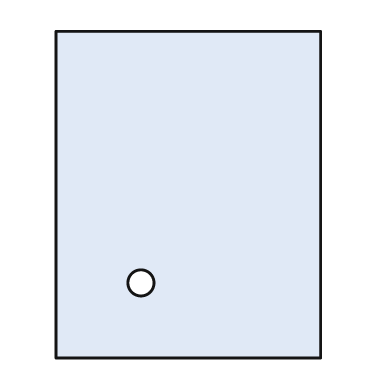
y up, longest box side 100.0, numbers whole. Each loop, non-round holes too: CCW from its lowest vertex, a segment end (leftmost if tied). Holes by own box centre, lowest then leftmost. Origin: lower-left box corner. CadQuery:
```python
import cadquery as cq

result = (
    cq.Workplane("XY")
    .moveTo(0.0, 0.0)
    .lineTo(81.0, 0.0)
    .lineTo(81.0, 100.0)
    .lineTo(0.0, 100.0)
    .close()
    .moveTo(26.0, 23.0)
    .circle(4.0)
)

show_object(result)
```